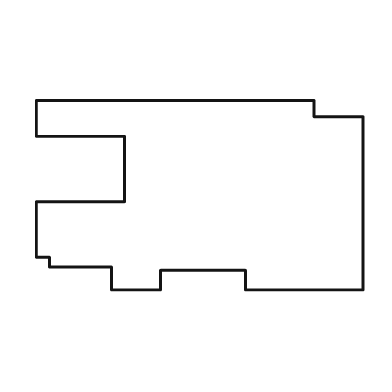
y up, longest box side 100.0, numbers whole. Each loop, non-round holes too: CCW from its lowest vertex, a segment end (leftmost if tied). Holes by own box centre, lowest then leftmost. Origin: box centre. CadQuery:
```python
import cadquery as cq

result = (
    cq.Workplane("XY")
    .moveTo(-27.0, -29.0)
    .lineTo(-12.0, -29.0)
    .lineTo(-12.0, -23.0)
    .lineTo(14.0, -23.0)
    .lineTo(14.0, -29.0)
    .lineTo(50.0, -29.0)
    .lineTo(50.0, 24.0)
    .lineTo(35.0, 24.0)
    .lineTo(35.0, 29.0)
    .lineTo(-50.0, 29.0)
    .lineTo(-50.0, 18.0)
    .lineTo(-23.0, 18.0)
    .lineTo(-23.0, -2.0)
    .lineTo(-50.0, -2.0)
    .lineTo(-50.0, -19.0)
    .lineTo(-46.0, -19.0)
    .lineTo(-46.0, -22.0)
    .lineTo(-27.0, -22.0)
    .close()
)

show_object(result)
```